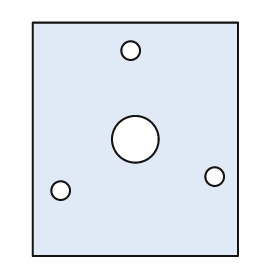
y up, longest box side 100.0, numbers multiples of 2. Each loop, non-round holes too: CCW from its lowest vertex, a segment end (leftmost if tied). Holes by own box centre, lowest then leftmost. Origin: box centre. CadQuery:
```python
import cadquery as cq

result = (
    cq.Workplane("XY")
    .moveTo(-44.0, -50.0)
    .lineTo(44.0, -50.0)
    .lineTo(44.0, 50.0)
    .lineTo(-44.0, 50.0)
    .close()
    .moveTo(-32.0, -22.0)
    .circle(4.0)
    .moveTo(34.0, -16.0)
    .circle(4.0)
    .moveTo(0.0, 0.0)
    .circle(10.0)
    .moveTo(-2.0, 38.0)
    .circle(4.0)
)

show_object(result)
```